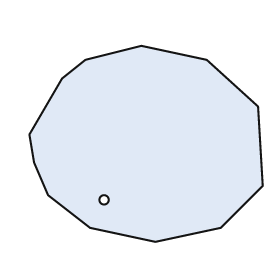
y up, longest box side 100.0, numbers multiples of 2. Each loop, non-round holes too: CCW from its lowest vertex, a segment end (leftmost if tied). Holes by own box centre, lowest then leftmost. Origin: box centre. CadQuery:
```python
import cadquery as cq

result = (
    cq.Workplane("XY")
    .moveTo(4.0, -42.0)
    .lineTo(32.0, -36.0)
    .lineTo(50.0, -18.0)
    .lineTo(48.0, 16.0)
    .lineTo(26.0, 36.0)
    .lineTo(-2.0, 42.0)
    .lineTo(-26.0, 36.0)
    .lineTo(-36.0, 28.0)
    .lineTo(-50.0, 4.0)
    .lineTo(-48.0, -8.0)
    .lineTo(-42.0, -22.0)
    .lineTo(-24.0, -36.0)
    .close()
    .moveTo(-18.0, -24.0)
    .circle(2.0)
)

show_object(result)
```